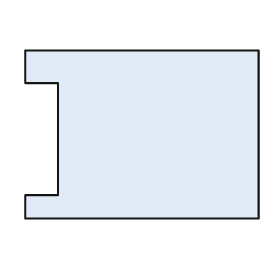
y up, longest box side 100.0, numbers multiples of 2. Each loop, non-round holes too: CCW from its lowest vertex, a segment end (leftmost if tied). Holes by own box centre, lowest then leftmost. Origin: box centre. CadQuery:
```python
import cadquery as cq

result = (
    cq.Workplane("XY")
    .moveTo(-50.0, -36.0)
    .lineTo(50.0, -36.0)
    .lineTo(50.0, 36.0)
    .lineTo(-50.0, 36.0)
    .lineTo(-50.0, 22.0)
    .lineTo(-36.0, 22.0)
    .lineTo(-36.0, -26.0)
    .lineTo(-50.0, -26.0)
    .close()
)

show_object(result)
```